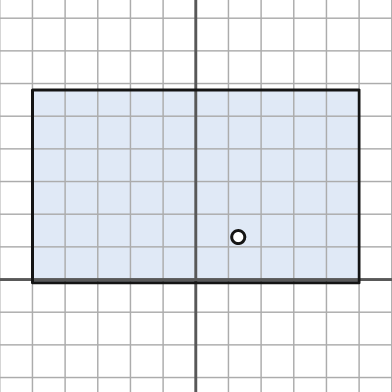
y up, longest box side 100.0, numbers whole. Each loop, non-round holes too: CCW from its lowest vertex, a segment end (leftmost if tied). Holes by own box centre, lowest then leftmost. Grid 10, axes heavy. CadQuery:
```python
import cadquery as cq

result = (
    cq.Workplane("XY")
    .moveTo(-50.0, -1.0)
    .lineTo(50.0, -1.0)
    .lineTo(50.0, 58.0)
    .lineTo(-50.0, 58.0)
    .close()
    .moveTo(13.0, 13.0)
    .circle(2.0)
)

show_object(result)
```